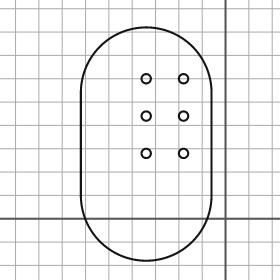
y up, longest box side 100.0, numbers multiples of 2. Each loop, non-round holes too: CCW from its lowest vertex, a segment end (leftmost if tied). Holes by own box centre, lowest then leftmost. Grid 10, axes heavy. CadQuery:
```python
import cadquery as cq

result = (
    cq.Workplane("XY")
    .moveTo(-62.0, 10.0)
    .threePointArc((-34.0, -18.0), (-6.0, 10.0))
    .lineTo(-6.0, 54.0)
    .threePointArc((-34.0, 82.0), (-62.0, 54.0))
    .close()
    .moveTo(-34.0, 28.0)
    .circle(2.0)
    .moveTo(-18.0, 28.0)
    .circle(2.0)
    .moveTo(-34.0, 44.0)
    .circle(2.0)
    .moveTo(-18.0, 44.0)
    .circle(2.0)
    .moveTo(-34.0, 60.0)
    .circle(2.0)
    .moveTo(-18.0, 60.0)
    .circle(2.0)
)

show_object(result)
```